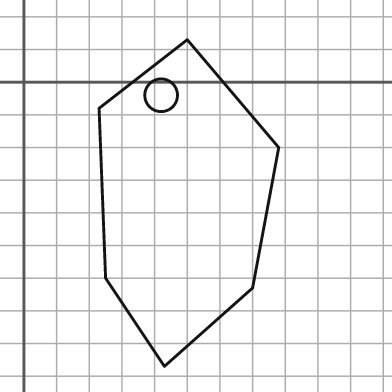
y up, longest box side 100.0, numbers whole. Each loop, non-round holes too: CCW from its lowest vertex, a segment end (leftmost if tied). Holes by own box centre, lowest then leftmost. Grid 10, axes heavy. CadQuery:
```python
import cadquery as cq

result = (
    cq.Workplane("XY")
    .moveTo(43.0, -87.0)
    .lineTo(70.0, -63.0)
    .lineTo(78.0, -20.0)
    .lineTo(50.0, 13.0)
    .lineTo(23.0, -8.0)
    .lineTo(25.0, -60.0)
    .close()
    .moveTo(42.0, -4.0)
    .circle(5.0)
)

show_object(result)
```